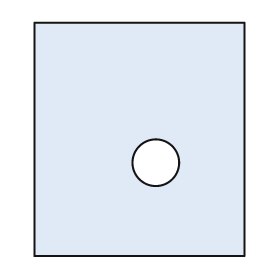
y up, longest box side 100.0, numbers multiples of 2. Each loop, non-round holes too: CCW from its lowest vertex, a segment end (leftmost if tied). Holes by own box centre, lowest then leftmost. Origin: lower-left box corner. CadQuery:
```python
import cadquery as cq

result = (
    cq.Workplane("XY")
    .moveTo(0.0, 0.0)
    .lineTo(90.0, 0.0)
    .lineTo(90.0, 100.0)
    .lineTo(0.0, 100.0)
    .close()
    .moveTo(52.0, 40.0)
    .circle(10.0)
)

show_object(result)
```